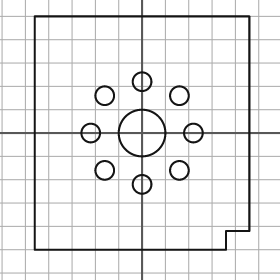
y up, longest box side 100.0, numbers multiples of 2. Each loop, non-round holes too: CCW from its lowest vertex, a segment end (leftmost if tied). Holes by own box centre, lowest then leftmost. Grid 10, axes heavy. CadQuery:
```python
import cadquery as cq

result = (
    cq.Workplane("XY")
    .moveTo(-46.0, -50.0)
    .lineTo(36.0, -50.0)
    .lineTo(36.0, -42.0)
    .lineTo(46.0, -42.0)
    .lineTo(46.0, 50.0)
    .lineTo(-46.0, 50.0)
    .close()
    .moveTo(0.0, -22.0)
    .circle(4.0)
    .moveTo(-16.0, -16.0)
    .circle(4.0)
    .moveTo(16.0, -16.0)
    .circle(4.0)
    .moveTo(-22.0, 0.0)
    .circle(4.0)
    .moveTo(0.0, 0.0)
    .circle(10.0)
    .moveTo(22.0, 0.0)
    .circle(4.0)
    .moveTo(-16.0, 16.0)
    .circle(4.0)
    .moveTo(16.0, 16.0)
    .circle(4.0)
    .moveTo(0.0, 22.0)
    .circle(4.0)
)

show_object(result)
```